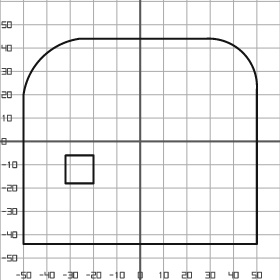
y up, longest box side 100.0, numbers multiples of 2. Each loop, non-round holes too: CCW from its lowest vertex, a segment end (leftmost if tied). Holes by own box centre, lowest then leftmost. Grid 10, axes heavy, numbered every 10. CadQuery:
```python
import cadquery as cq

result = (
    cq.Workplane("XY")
    .moveTo(-50.0, -44.0)
    .lineTo(50.0, -44.0)
    .lineTo(50.0, 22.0)
    .threePointArc((44.0, 38.0), (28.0, 44.0))
    .lineTo(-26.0, 44.0)
    .threePointArc((-42.0, 36.0), (-50.0, 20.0))
    .close()
    .moveTo(-32.0, -18.0)
    .lineTo(-20.0, -18.0)
    .lineTo(-20.0, -6.0)
    .lineTo(-32.0, -6.0)
    .close()
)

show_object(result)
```